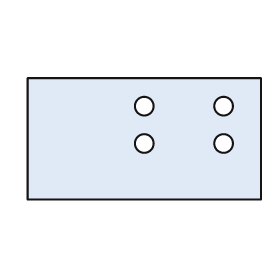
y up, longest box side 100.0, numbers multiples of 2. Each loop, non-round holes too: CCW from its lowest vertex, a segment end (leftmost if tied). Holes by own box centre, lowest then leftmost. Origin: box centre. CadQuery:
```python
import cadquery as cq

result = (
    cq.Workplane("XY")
    .moveTo(-50.0, -26.0)
    .lineTo(50.0, -26.0)
    .lineTo(50.0, 26.0)
    .lineTo(-50.0, 26.0)
    .close()
    .moveTo(0.0, -2.0)
    .circle(4.0)
    .moveTo(34.0, -2.0)
    .circle(4.0)
    .moveTo(0.0, 14.0)
    .circle(4.0)
    .moveTo(34.0, 14.0)
    .circle(4.0)
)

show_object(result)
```